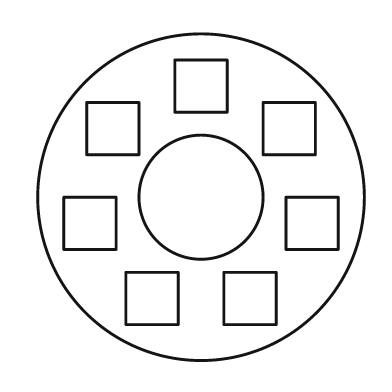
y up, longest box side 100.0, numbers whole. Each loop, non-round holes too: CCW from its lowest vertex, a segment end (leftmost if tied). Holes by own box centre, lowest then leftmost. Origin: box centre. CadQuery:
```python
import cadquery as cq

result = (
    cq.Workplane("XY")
    .moveTo(0.0, 0.0)
    .circle(50.0)
    .moveTo(-23.0, -39.0)
    .lineTo(-7.0, -39.0)
    .lineTo(-7.0, -23.0)
    .lineTo(-23.0, -23.0)
    .close()
    .moveTo(7.0, -39.0)
    .lineTo(23.0, -39.0)
    .lineTo(23.0, -23.0)
    .lineTo(7.0, -23.0)
    .close()
    .moveTo(-42.0, -16.0)
    .lineTo(-26.0, -16.0)
    .lineTo(-26.0, 0.0)
    .lineTo(-42.0, 0.0)
    .close()
    .moveTo(26.0, -16.0)
    .lineTo(42.0, -16.0)
    .lineTo(42.0, 0.0)
    .lineTo(26.0, 0.0)
    .close()
    .moveTo(0.0, 0.0)
    .circle(19.0)
    .moveTo(-35.0, 13.0)
    .lineTo(-19.0, 13.0)
    .lineTo(-19.0, 29.0)
    .lineTo(-35.0, 29.0)
    .close()
    .moveTo(19.0, 13.0)
    .lineTo(35.0, 13.0)
    .lineTo(35.0, 29.0)
    .lineTo(19.0, 29.0)
    .close()
    .moveTo(-8.0, 26.0)
    .lineTo(8.0, 26.0)
    .lineTo(8.0, 42.0)
    .lineTo(-8.0, 42.0)
    .close()
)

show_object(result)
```